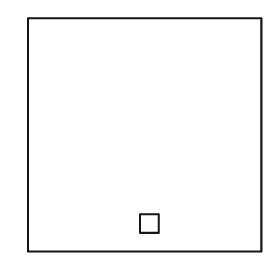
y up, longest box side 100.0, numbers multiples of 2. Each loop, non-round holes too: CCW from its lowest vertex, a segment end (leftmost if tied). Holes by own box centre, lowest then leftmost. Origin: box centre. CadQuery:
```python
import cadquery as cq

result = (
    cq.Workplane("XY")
    .moveTo(-50.0, -50.0)
    .lineTo(50.0, -50.0)
    .lineTo(50.0, 50.0)
    .lineTo(-50.0, 50.0)
    .close()
    .moveTo(-2.0, -42.0)
    .lineTo(6.0, -42.0)
    .lineTo(6.0, -34.0)
    .lineTo(-2.0, -34.0)
    .close()
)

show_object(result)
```